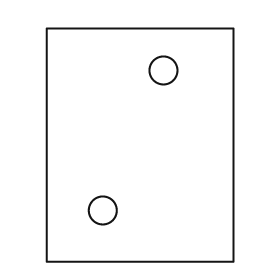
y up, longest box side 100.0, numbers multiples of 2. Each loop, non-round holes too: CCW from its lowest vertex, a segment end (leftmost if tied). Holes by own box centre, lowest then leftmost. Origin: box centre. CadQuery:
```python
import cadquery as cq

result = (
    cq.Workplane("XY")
    .moveTo(-40.0, -50.0)
    .lineTo(40.0, -50.0)
    .lineTo(40.0, 50.0)
    .lineTo(-40.0, 50.0)
    .close()
    .moveTo(-16.0, -28.0)
    .circle(6.0)
    .moveTo(10.0, 32.0)
    .circle(6.0)
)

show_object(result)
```